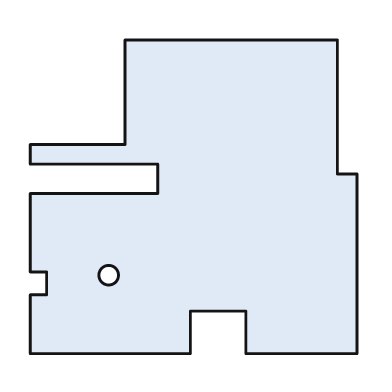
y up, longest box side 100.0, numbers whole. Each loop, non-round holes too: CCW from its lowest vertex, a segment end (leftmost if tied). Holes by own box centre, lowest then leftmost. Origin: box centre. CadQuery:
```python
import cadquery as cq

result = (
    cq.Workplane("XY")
    .moveTo(-50.0, -48.0)
    .lineTo(-1.0, -48.0)
    .lineTo(-1.0, -35.0)
    .lineTo(16.0, -35.0)
    .lineTo(16.0, -48.0)
    .lineTo(50.0, -48.0)
    .lineTo(50.0, 7.0)
    .lineTo(44.0, 7.0)
    .lineTo(44.0, 48.0)
    .lineTo(-21.0, 48.0)
    .lineTo(-21.0, 16.0)
    .lineTo(-50.0, 16.0)
    .lineTo(-50.0, 10.0)
    .lineTo(-11.0, 10.0)
    .lineTo(-11.0, 1.0)
    .lineTo(-50.0, 1.0)
    .lineTo(-50.0, -23.0)
    .lineTo(-45.0, -23.0)
    .lineTo(-45.0, -30.0)
    .lineTo(-50.0, -30.0)
    .close()
    .moveTo(-26.0, -24.0)
    .circle(3.0)
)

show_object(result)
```